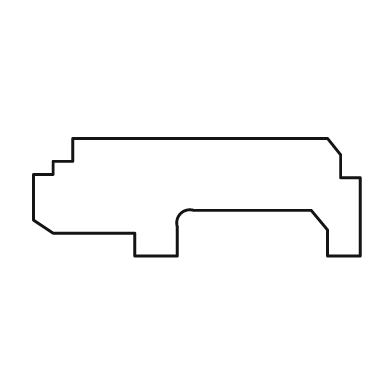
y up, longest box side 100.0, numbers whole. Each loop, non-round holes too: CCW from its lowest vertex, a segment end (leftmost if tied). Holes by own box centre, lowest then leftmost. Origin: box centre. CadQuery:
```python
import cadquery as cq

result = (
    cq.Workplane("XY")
    .moveTo(-19.0, -18.0)
    .lineTo(-6.0, -18.0)
    .lineTo(-6.0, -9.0)
    .threePointArc((-5.0, -5.0), (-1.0, -4.0))
    .lineTo(35.0, -4.0)
    .lineTo(40.0, -10.0)
    .lineTo(40.0, -18.0)
    .lineTo(50.0, -18.0)
    .lineTo(50.0, 6.0)
    .lineTo(44.0, 6.0)
    .lineTo(44.0, 13.0)
    .lineTo(40.0, 18.0)
    .lineTo(-38.0, 18.0)
    .lineTo(-38.0, 11.0)
    .lineTo(-44.0, 11.0)
    .lineTo(-44.0, 7.0)
    .lineTo(-50.0, 7.0)
    .lineTo(-50.0, -7.0)
    .lineTo(-44.0, -11.0)
    .lineTo(-19.0, -11.0)
    .close()
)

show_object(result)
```